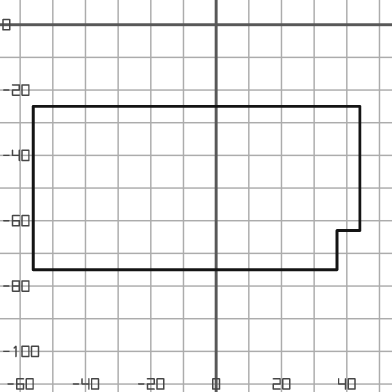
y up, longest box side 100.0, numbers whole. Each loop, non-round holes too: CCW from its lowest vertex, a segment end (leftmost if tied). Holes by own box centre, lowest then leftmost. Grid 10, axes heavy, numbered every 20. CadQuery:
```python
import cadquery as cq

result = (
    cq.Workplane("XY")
    .moveTo(-56.0, -75.0)
    .lineTo(37.0, -75.0)
    .lineTo(37.0, -63.0)
    .lineTo(44.0, -63.0)
    .lineTo(44.0, -25.0)
    .lineTo(-56.0, -25.0)
    .close()
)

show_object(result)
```